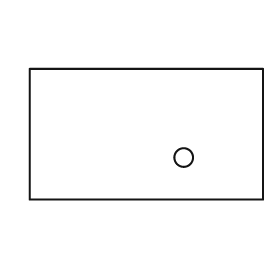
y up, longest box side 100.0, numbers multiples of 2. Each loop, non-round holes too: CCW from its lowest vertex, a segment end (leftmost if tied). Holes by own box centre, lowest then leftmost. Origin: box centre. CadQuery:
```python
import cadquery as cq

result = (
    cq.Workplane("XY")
    .moveTo(-50.0, -28.0)
    .lineTo(50.0, -28.0)
    .lineTo(50.0, 28.0)
    .lineTo(-50.0, 28.0)
    .close()
    .moveTo(16.0, -10.0)
    .circle(4.0)
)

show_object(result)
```